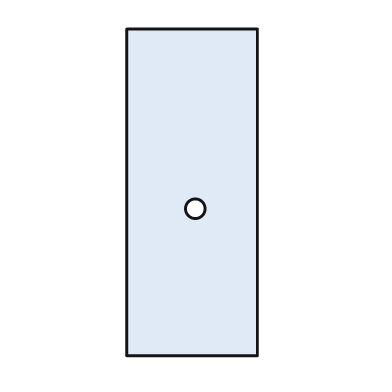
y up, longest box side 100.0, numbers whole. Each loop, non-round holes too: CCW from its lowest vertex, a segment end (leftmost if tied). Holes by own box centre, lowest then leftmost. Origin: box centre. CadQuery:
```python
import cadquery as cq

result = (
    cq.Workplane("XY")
    .moveTo(-20.0, -50.0)
    .lineTo(20.0, -50.0)
    .lineTo(20.0, 50.0)
    .lineTo(-20.0, 50.0)
    .close()
    .moveTo(1.0, -5.0)
    .circle(3.0)
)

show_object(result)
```